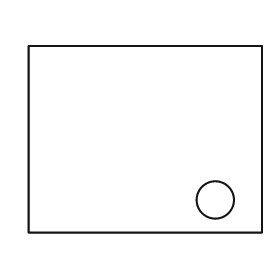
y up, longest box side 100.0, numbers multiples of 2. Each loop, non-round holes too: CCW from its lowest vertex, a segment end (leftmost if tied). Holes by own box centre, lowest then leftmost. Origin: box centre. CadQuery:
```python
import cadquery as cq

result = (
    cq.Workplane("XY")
    .moveTo(-50.0, -40.0)
    .lineTo(50.0, -40.0)
    .lineTo(50.0, 40.0)
    .lineTo(-50.0, 40.0)
    .close()
    .moveTo(30.0, -26.0)
    .circle(8.0)
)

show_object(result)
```